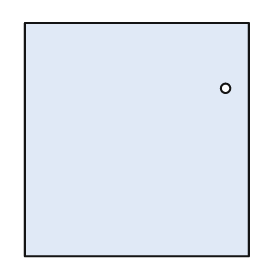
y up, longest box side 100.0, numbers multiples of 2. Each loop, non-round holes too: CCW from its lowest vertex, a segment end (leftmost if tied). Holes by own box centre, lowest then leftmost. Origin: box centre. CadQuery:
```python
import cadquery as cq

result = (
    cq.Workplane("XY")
    .moveTo(-48.0, -50.0)
    .lineTo(48.0, -50.0)
    .lineTo(48.0, 50.0)
    .lineTo(-48.0, 50.0)
    .close()
    .moveTo(38.0, 22.0)
    .circle(2.0)
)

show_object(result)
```